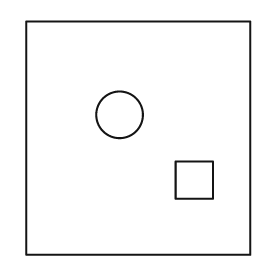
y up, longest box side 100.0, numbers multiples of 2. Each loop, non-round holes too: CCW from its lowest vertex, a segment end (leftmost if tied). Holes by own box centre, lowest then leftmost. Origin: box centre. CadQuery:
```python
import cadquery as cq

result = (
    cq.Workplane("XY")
    .moveTo(-48.0, -50.0)
    .lineTo(48.0, -50.0)
    .lineTo(48.0, 50.0)
    .lineTo(-48.0, 50.0)
    .close()
    .moveTo(16.0, -26.0)
    .lineTo(32.0, -26.0)
    .lineTo(32.0, -10.0)
    .lineTo(16.0, -10.0)
    .close()
    .moveTo(-8.0, 10.0)
    .circle(10.0)
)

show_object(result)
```